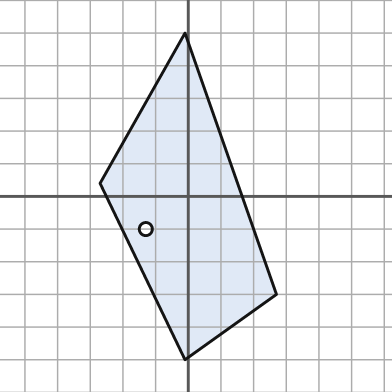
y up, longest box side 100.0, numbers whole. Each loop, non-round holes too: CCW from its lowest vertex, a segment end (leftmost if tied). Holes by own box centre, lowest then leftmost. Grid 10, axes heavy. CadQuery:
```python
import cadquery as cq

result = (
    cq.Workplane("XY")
    .moveTo(-1.0, -50.0)
    .lineTo(27.0, -30.0)
    .lineTo(-1.0, 50.0)
    .lineTo(-27.0, 4.0)
    .close()
    .moveTo(-13.0, -10.0)
    .circle(2.0)
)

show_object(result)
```